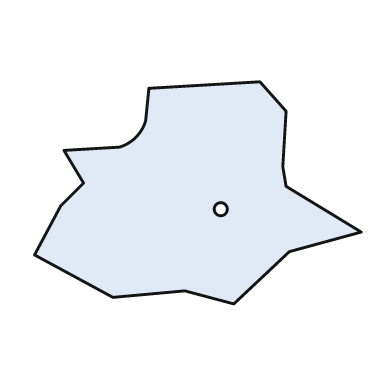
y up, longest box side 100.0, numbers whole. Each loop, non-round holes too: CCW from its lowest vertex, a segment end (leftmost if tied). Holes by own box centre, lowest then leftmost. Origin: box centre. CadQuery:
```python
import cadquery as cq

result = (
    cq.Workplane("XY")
    .moveTo(11.0, -34.0)
    .lineTo(28.0, -18.0)
    .lineTo(50.0, -12.0)
    .lineTo(27.0, 2.0)
    .lineTo(26.0, 8.0)
    .lineTo(27.0, 25.0)
    .lineTo(19.0, 34.0)
    .lineTo(-15.0, 32.0)
    .lineTo(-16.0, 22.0)
    .threePointArc((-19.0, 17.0), (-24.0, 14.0))
    .lineTo(-41.0, 13.0)
    .lineTo(-35.0, 3.0)
    .lineTo(-42.0, -4.0)
    .lineTo(-50.0, -19.0)
    .lineTo(-26.0, -32.0)
    .lineTo(-4.0, -30.0)
    .close()
    .moveTo(7.0, -5.0)
    .circle(2.0)
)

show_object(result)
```